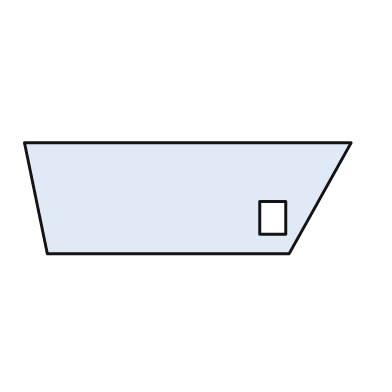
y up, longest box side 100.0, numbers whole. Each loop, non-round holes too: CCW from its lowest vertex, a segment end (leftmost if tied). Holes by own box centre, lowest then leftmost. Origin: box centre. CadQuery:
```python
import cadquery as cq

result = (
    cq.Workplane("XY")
    .moveTo(-43.0, -17.0)
    .lineTo(31.0, -17.0)
    .lineTo(50.0, 17.0)
    .lineTo(-50.0, 17.0)
    .close()
    .moveTo(22.0, -11.0)
    .lineTo(30.0, -11.0)
    .lineTo(30.0, -1.0)
    .lineTo(22.0, -1.0)
    .close()
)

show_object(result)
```